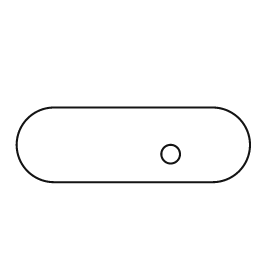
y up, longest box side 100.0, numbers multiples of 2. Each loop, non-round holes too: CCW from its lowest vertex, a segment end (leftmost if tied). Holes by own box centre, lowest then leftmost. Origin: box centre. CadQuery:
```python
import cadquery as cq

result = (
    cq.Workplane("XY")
    .moveTo(-34.0, -16.0)
    .lineTo(34.0, -16.0)
    .threePointArc((50.0, 0.0), (34.0, 16.0))
    .lineTo(-34.0, 16.0)
    .threePointArc((-50.0, 0.0), (-34.0, -16.0))
    .close()
    .moveTo(16.0, -4.0)
    .circle(4.0)
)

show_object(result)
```